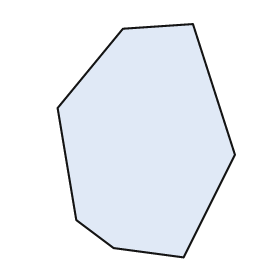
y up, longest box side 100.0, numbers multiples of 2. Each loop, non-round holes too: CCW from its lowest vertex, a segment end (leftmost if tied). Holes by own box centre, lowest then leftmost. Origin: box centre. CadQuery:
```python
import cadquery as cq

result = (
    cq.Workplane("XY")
    .moveTo(16.0, -50.0)
    .lineTo(38.0, -6.0)
    .lineTo(20.0, 50.0)
    .lineTo(-10.0, 48.0)
    .lineTo(-38.0, 14.0)
    .lineTo(-30.0, -34.0)
    .lineTo(-14.0, -46.0)
    .close()
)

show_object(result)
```